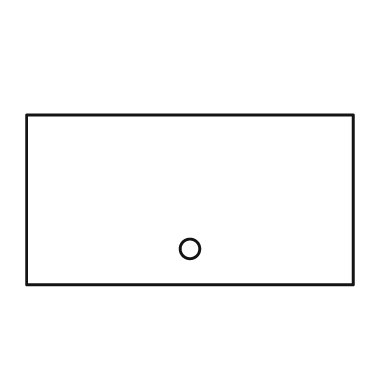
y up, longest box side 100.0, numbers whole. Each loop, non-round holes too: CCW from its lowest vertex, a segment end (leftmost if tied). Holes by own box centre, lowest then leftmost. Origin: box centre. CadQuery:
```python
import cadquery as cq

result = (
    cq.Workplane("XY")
    .moveTo(-50.0, -26.0)
    .lineTo(50.0, -26.0)
    .lineTo(50.0, 26.0)
    .lineTo(-50.0, 26.0)
    .close()
    .moveTo(0.0, -15.0)
    .circle(3.0)
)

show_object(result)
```